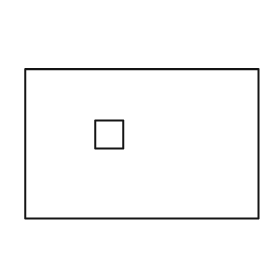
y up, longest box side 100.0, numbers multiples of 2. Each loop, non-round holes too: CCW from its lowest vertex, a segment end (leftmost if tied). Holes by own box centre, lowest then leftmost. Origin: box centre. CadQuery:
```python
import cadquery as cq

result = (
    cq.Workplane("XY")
    .moveTo(-50.0, -32.0)
    .lineTo(50.0, -32.0)
    .lineTo(50.0, 32.0)
    .lineTo(-50.0, 32.0)
    .close()
    .moveTo(-20.0, -2.0)
    .lineTo(-8.0, -2.0)
    .lineTo(-8.0, 10.0)
    .lineTo(-20.0, 10.0)
    .close()
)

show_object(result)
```